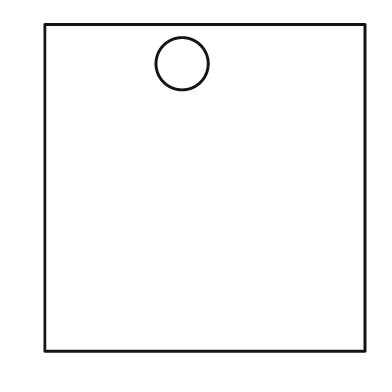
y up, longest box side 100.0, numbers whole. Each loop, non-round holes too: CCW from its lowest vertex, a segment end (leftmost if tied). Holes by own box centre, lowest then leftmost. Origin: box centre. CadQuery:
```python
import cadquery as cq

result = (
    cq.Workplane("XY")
    .moveTo(-49.0, -50.0)
    .lineTo(49.0, -50.0)
    .lineTo(49.0, 50.0)
    .lineTo(-49.0, 50.0)
    .close()
    .moveTo(-7.0, 38.0)
    .circle(8.0)
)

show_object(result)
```